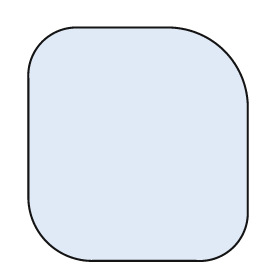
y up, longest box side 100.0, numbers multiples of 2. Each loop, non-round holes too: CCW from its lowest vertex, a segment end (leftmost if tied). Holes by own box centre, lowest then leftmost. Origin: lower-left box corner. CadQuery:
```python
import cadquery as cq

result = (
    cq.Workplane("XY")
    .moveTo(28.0, 0.0)
    .lineTo(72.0, 0.0)
    .threePointArc((88.0, 6.0), (94.0, 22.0))
    .lineTo(94.0, 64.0)
    .threePointArc((84.0, 90.0), (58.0, 100.0))
    .lineTo(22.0, 100.0)
    .threePointArc((6.0, 94.0), (0.0, 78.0))
    .lineTo(0.0, 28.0)
    .threePointArc((8.0, 8.0), (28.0, 0.0))
    .close()
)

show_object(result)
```